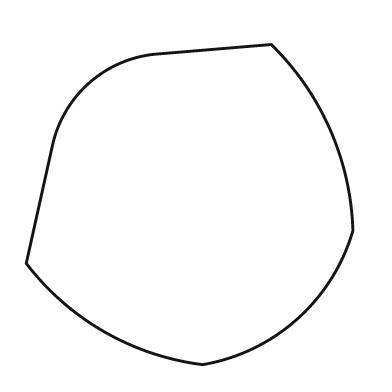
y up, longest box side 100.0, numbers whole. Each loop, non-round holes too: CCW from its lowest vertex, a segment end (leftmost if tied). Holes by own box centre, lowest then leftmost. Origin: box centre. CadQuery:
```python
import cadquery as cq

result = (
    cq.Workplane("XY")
    .moveTo(4.0, -49.0)
    .threePointArc((33.0, -35.0), (50.0, -8.0))
    .threePointArc((43.0, 23.0), (25.0, 49.0))
    .lineTo(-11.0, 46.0)
    .threePointArc((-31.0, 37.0), (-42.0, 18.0))
    .lineTo(-50.0, -18.0)
    .threePointArc((-26.0, -39.0), (4.0, -49.0))
    .close()
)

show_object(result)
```